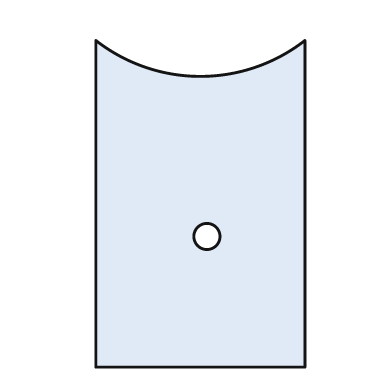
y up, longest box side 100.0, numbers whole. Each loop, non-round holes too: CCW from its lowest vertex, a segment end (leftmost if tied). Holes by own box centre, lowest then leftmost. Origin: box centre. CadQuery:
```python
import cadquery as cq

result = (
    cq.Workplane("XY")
    .moveTo(-32.0, -50.0)
    .lineTo(32.0, -50.0)
    .lineTo(32.0, 50.0)
    .threePointArc((0.0, 39.0), (-32.0, 50.0))
    .close()
    .moveTo(2.0, -10.0)
    .circle(4.0)
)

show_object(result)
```